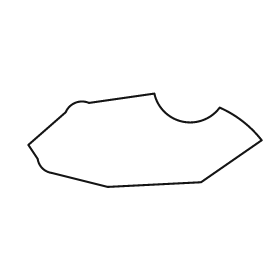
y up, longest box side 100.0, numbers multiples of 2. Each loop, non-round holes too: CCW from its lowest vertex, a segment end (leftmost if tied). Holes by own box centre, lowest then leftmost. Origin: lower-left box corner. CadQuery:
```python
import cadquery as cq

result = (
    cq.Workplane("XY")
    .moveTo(34.0, 0.0)
    .lineTo(74.0, 2.0)
    .lineTo(100.0, 20.0)
    .threePointArc((92.0, 28.0), (82.0, 34.0))
    .threePointArc((66.0, 28.0), (54.0, 40.0))
    .lineTo(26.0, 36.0)
    .threePointArc((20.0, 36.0), (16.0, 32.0))
    .lineTo(0.0, 18.0)
    .lineTo(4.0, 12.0)
    .threePointArc((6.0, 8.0), (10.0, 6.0))
    .close()
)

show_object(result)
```